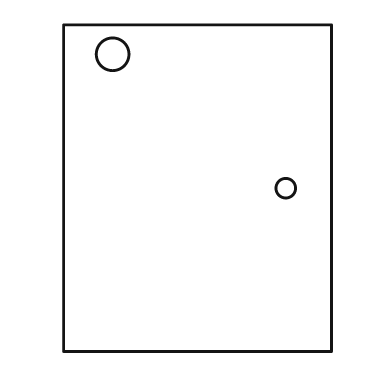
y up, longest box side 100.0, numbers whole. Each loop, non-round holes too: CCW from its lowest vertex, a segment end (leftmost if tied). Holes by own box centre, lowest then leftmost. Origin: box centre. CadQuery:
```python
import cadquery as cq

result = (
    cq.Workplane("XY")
    .moveTo(-41.0, -50.0)
    .lineTo(41.0, -50.0)
    .lineTo(41.0, 50.0)
    .lineTo(-41.0, 50.0)
    .close()
    .moveTo(27.0, 0.0)
    .circle(3.0)
    .moveTo(-26.0, 41.0)
    .circle(5.0)
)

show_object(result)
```